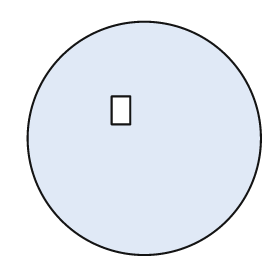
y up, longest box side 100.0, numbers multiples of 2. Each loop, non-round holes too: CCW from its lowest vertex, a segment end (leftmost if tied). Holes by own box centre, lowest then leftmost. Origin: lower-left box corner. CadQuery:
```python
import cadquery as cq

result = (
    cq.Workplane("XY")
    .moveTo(50.0, 50.0)
    .circle(50.0)
    .moveTo(36.0, 56.0)
    .lineTo(44.0, 56.0)
    .lineTo(44.0, 68.0)
    .lineTo(36.0, 68.0)
    .close()
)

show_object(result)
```